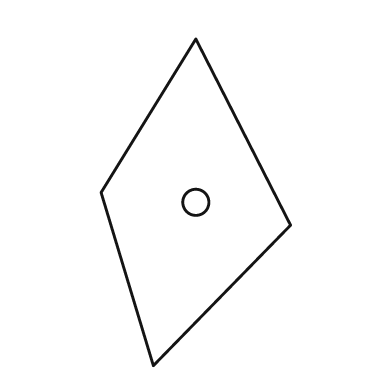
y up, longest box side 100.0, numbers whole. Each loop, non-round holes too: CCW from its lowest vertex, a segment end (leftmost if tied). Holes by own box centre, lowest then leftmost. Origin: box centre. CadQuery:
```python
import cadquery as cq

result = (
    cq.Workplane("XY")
    .moveTo(-13.0, -50.0)
    .lineTo(29.0, -7.0)
    .lineTo(0.0, 50.0)
    .lineTo(-29.0, 3.0)
    .close()
    .moveTo(0.0, 0.0)
    .circle(4.0)
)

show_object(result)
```